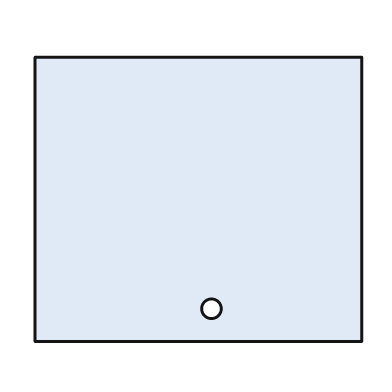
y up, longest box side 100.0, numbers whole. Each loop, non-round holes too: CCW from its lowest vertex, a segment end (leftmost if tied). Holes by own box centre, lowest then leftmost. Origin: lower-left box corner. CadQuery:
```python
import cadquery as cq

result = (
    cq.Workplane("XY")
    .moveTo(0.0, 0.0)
    .lineTo(100.0, 0.0)
    .lineTo(100.0, 87.0)
    .lineTo(0.0, 87.0)
    .close()
    .moveTo(54.0, 10.0)
    .circle(3.0)
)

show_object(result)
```